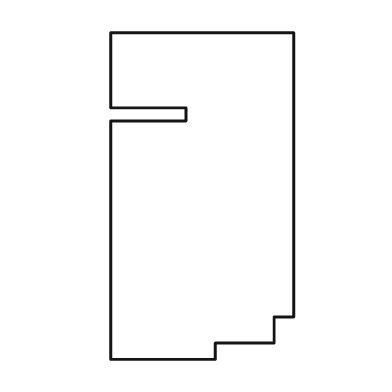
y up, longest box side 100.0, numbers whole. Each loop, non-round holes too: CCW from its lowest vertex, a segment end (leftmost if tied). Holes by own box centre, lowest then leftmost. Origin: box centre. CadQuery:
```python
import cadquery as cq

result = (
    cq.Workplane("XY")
    .moveTo(-28.0, -50.0)
    .lineTo(4.0, -50.0)
    .lineTo(4.0, -45.0)
    .lineTo(22.0, -45.0)
    .lineTo(22.0, -37.0)
    .lineTo(28.0, -37.0)
    .lineTo(28.0, 50.0)
    .lineTo(-28.0, 50.0)
    .lineTo(-28.0, 27.0)
    .lineTo(-5.0, 27.0)
    .lineTo(-5.0, 23.0)
    .lineTo(-28.0, 23.0)
    .close()
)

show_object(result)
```